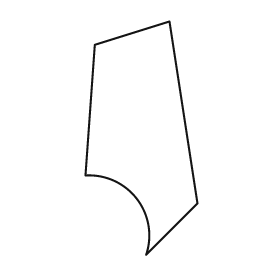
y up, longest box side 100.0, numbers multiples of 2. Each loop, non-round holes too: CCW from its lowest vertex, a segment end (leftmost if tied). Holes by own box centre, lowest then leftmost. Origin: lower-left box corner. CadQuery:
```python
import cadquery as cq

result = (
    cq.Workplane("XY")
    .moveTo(26.0, 0.0)
    .lineTo(48.0, 22.0)
    .lineTo(36.0, 100.0)
    .lineTo(4.0, 90.0)
    .lineTo(0.0, 34.0)
    .threePointArc((22.0, 24.0), (26.0, 0.0))
    .close()
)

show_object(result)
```